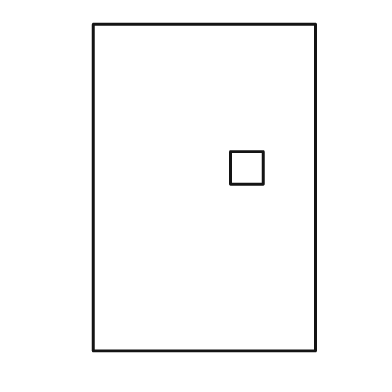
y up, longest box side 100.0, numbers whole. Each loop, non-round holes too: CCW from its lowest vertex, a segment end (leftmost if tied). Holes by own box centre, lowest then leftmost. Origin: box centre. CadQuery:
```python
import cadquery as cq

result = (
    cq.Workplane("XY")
    .moveTo(-34.0, -50.0)
    .lineTo(34.0, -50.0)
    .lineTo(34.0, 50.0)
    .lineTo(-34.0, 50.0)
    .close()
    .moveTo(8.0, 1.0)
    .lineTo(18.0, 1.0)
    .lineTo(18.0, 11.0)
    .lineTo(8.0, 11.0)
    .close()
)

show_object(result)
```